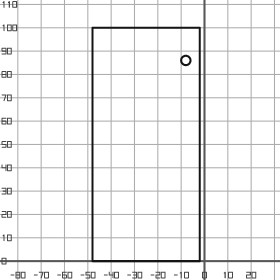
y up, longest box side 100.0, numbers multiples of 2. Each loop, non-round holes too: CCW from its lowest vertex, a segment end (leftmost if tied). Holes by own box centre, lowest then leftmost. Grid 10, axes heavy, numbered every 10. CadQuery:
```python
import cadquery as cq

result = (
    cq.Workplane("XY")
    .moveTo(-48.0, 0.0)
    .lineTo(-2.0, 0.0)
    .lineTo(-2.0, 100.0)
    .lineTo(-48.0, 100.0)
    .close()
    .moveTo(-8.0, 86.0)
    .circle(2.0)
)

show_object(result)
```